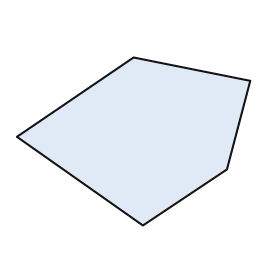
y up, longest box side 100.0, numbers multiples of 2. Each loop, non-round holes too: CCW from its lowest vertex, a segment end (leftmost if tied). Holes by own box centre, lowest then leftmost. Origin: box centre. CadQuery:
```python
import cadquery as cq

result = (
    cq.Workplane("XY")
    .moveTo(4.0, -36.0)
    .lineTo(40.0, -12.0)
    .lineTo(50.0, 26.0)
    .lineTo(0.0, 36.0)
    .lineTo(-50.0, 2.0)
    .close()
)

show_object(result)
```